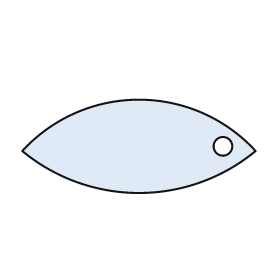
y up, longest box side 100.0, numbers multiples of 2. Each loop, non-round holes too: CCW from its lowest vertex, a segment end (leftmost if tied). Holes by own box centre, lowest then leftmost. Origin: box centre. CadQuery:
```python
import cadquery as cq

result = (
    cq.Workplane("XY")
    .moveTo(-50.0, -2.0)
    .threePointArc((0.0, -20.0), (50.0, -2.0))
    .threePointArc((0.0, 20.0), (-50.0, -2.0))
    .close()
    .moveTo(36.0, 0.0)
    .circle(4.0)
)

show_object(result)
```